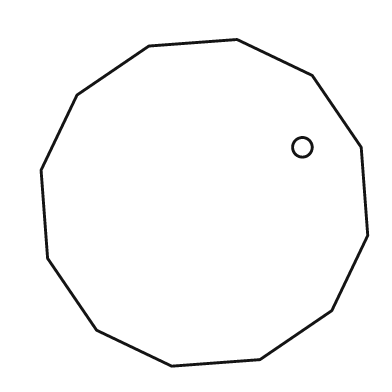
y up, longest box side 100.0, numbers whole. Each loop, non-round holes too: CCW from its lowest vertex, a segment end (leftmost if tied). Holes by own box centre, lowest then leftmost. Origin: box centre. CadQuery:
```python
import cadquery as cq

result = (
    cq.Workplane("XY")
    .moveTo(-10.0, -50.0)
    .lineTo(17.0, -48.0)
    .lineTo(39.0, -33.0)
    .lineTo(50.0, -10.0)
    .lineTo(48.0, 17.0)
    .lineTo(33.0, 39.0)
    .lineTo(10.0, 50.0)
    .lineTo(-17.0, 48.0)
    .lineTo(-39.0, 33.0)
    .lineTo(-50.0, 10.0)
    .lineTo(-48.0, -17.0)
    .lineTo(-33.0, -39.0)
    .close()
    .moveTo(30.0, 17.0)
    .circle(3.0)
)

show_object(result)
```